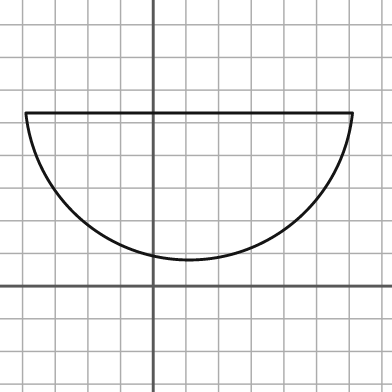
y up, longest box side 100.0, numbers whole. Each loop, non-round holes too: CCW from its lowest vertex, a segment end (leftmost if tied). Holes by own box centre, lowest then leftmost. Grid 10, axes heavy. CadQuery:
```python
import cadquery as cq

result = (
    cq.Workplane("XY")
    .moveTo(-39.0, 53.0)
    .threePointArc((11.0, 8.0), (61.0, 53.0))
    .close()
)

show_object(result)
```